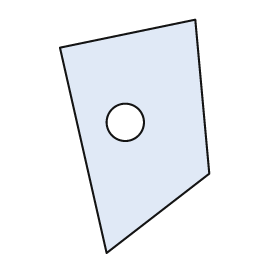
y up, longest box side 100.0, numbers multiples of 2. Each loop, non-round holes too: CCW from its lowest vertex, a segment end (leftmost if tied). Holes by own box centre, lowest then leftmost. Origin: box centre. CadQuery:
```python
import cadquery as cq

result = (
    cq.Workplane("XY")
    .moveTo(-12.0, -50.0)
    .lineTo(32.0, -16.0)
    .lineTo(26.0, 50.0)
    .lineTo(-32.0, 38.0)
    .close()
    .moveTo(-4.0, 6.0)
    .circle(8.0)
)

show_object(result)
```